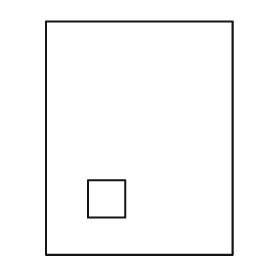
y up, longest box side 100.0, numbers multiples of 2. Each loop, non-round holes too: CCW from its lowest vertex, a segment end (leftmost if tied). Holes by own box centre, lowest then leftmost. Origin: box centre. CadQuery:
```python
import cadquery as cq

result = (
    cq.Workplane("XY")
    .moveTo(-40.0, -50.0)
    .lineTo(40.0, -50.0)
    .lineTo(40.0, 50.0)
    .lineTo(-40.0, 50.0)
    .close()
    .moveTo(-22.0, -34.0)
    .lineTo(-6.0, -34.0)
    .lineTo(-6.0, -18.0)
    .lineTo(-22.0, -18.0)
    .close()
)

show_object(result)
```